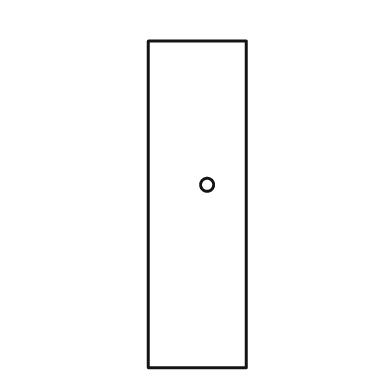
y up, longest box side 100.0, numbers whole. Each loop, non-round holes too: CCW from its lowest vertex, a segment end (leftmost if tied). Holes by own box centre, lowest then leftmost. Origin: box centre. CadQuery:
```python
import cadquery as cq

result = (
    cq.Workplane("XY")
    .moveTo(-15.0, -50.0)
    .lineTo(15.0, -50.0)
    .lineTo(15.0, 50.0)
    .lineTo(-15.0, 50.0)
    .close()
    .moveTo(3.0, 6.0)
    .circle(2.0)
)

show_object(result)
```